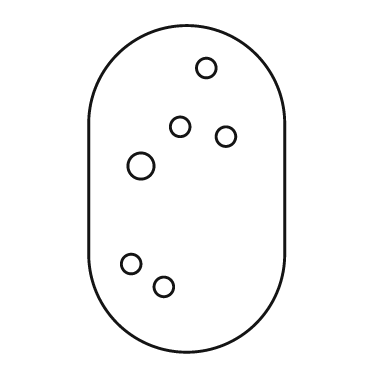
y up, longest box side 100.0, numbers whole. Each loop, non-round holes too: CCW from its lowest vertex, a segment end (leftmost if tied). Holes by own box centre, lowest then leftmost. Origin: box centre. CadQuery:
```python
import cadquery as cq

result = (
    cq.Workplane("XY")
    .moveTo(-30.0, -20.0)
    .threePointArc((0.0, -50.0), (30.0, -20.0))
    .lineTo(30.0, 20.0)
    .threePointArc((0.0, 50.0), (-30.0, 20.0))
    .close()
    .moveTo(-7.0, -30.0)
    .circle(3.0)
    .moveTo(-17.0, -23.0)
    .circle(3.0)
    .moveTo(-14.0, 7.0)
    .circle(4.0)
    .moveTo(12.0, 16.0)
    .circle(3.0)
    .moveTo(-2.0, 19.0)
    .circle(3.0)
    .moveTo(6.0, 37.0)
    .circle(3.0)
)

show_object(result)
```